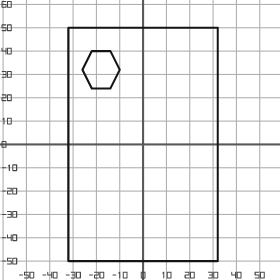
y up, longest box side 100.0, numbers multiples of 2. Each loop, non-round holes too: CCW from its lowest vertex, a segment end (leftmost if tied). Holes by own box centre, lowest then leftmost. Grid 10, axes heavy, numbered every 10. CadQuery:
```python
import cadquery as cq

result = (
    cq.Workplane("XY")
    .moveTo(-32.0, -50.0)
    .lineTo(32.0, -50.0)
    .lineTo(32.0, 50.0)
    .lineTo(-32.0, 50.0)
    .close()
    .moveTo(-22.0, 24.0)
    .lineTo(-14.0, 24.0)
    .lineTo(-10.0, 32.0)
    .lineTo(-14.0, 40.0)
    .lineTo(-22.0, 40.0)
    .lineTo(-26.0, 32.0)
    .close()
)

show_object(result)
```